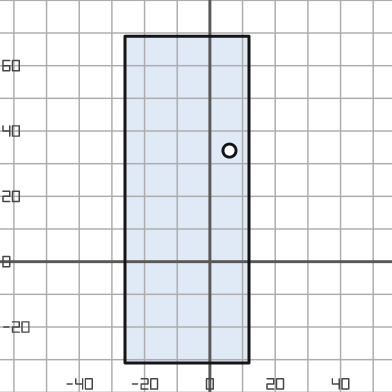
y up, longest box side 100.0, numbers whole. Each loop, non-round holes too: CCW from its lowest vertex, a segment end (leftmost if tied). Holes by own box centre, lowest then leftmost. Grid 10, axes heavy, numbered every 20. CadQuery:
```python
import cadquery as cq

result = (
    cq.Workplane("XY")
    .moveTo(-26.0, -31.0)
    .lineTo(12.0, -31.0)
    .lineTo(12.0, 69.0)
    .lineTo(-26.0, 69.0)
    .close()
    .moveTo(6.0, 34.0)
    .circle(2.0)
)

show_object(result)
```